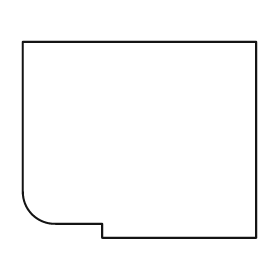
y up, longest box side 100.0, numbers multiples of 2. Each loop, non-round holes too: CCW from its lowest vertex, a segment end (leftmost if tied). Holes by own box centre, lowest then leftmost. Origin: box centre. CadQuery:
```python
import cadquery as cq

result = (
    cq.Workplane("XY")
    .moveTo(-16.0, -42.0)
    .lineTo(50.0, -42.0)
    .lineTo(50.0, 42.0)
    .lineTo(-50.0, 42.0)
    .lineTo(-50.0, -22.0)
    .threePointArc((-46.0, -32.0), (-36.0, -36.0))
    .lineTo(-16.0, -36.0)
    .close()
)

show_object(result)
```